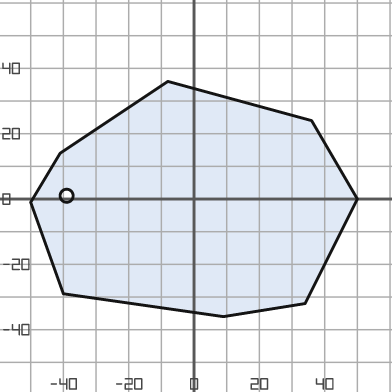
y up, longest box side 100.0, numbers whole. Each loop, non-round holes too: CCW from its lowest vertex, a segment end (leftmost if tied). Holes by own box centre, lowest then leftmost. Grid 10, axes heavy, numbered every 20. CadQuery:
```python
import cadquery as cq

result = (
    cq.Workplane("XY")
    .moveTo(9.0, -36.0)
    .lineTo(34.0, -32.0)
    .lineTo(50.0, 0.0)
    .lineTo(36.0, 24.0)
    .lineTo(-8.0, 36.0)
    .lineTo(-41.0, 14.0)
    .lineTo(-50.0, -1.0)
    .lineTo(-40.0, -29.0)
    .close()
    .moveTo(-39.0, 1.0)
    .circle(2.0)
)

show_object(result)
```